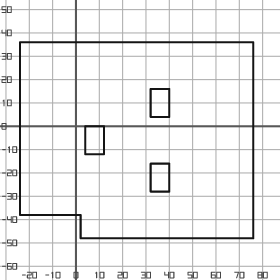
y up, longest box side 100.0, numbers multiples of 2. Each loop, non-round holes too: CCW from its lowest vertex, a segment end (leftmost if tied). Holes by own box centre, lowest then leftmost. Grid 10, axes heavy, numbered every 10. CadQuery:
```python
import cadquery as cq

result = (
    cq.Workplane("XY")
    .moveTo(2.0, -48.0)
    .lineTo(76.0, -48.0)
    .lineTo(76.0, 36.0)
    .lineTo(-24.0, 36.0)
    .lineTo(-24.0, -38.0)
    .lineTo(2.0, -38.0)
    .close()
    .moveTo(32.0, -28.0)
    .lineTo(40.0, -28.0)
    .lineTo(40.0, -16.0)
    .lineTo(32.0, -16.0)
    .close()
    .moveTo(4.0, -12.0)
    .lineTo(12.0, -12.0)
    .lineTo(12.0, 0.0)
    .lineTo(4.0, 0.0)
    .close()
    .moveTo(32.0, 4.0)
    .lineTo(40.0, 4.0)
    .lineTo(40.0, 16.0)
    .lineTo(32.0, 16.0)
    .close()
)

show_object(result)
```